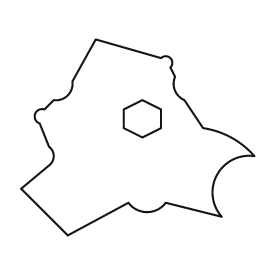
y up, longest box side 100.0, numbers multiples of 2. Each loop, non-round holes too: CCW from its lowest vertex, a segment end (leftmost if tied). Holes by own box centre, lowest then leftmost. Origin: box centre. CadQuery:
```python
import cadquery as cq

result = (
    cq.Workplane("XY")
    .moveTo(-30.0, -42.0)
    .lineTo(-4.0, -28.0)
    .threePointArc((4.0, -32.0), (12.0, -28.0))
    .lineTo(36.0, -34.0)
    .threePointArc((34.0, -16.0), (50.0, -8.0))
    .threePointArc((40.0, 0.0), (28.0, 4.0))
    .lineTo(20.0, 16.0)
    .threePointArc((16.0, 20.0), (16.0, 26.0))
    .lineTo(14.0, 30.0)
    .threePointArc((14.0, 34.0), (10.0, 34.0))
    .lineTo(-18.0, 42.0)
    .lineTo(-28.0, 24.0)
    .threePointArc((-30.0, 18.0), (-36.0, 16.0))
    .lineTo(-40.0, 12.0)
    .threePointArc((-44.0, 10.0), (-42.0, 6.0))
    .lineTo(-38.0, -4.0)
    .threePointArc((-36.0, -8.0), (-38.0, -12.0))
    .lineTo(-50.0, -22.0)
    .close()
    .moveTo(2.0, 0.0)
    .lineTo(10.0, 4.0)
    .lineTo(10.0, 12.0)
    .lineTo(2.0, 16.0)
    .lineTo(-6.0, 12.0)
    .lineTo(-6.0, 4.0)
    .close()
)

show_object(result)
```